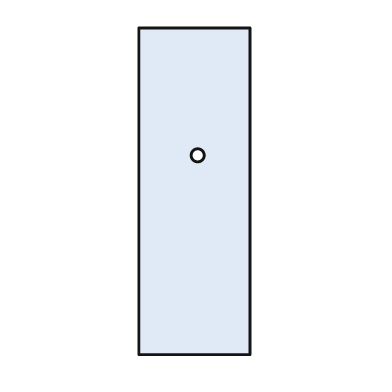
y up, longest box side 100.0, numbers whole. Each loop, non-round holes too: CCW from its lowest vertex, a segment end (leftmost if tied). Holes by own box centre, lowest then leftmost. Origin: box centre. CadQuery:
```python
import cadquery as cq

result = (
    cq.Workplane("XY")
    .moveTo(-17.0, -50.0)
    .lineTo(17.0, -50.0)
    .lineTo(17.0, 50.0)
    .lineTo(-17.0, 50.0)
    .close()
    .moveTo(1.0, 11.0)
    .circle(2.0)
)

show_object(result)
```